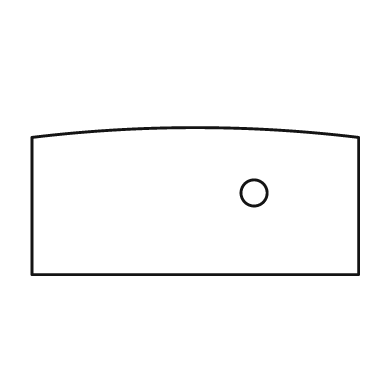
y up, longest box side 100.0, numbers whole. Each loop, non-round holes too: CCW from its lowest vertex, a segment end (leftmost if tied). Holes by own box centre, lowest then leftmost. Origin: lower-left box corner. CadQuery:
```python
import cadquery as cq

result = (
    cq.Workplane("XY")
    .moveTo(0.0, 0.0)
    .lineTo(100.0, 0.0)
    .lineTo(100.0, 42.0)
    .threePointArc((50.0, 45.0), (0.0, 42.0))
    .close()
    .moveTo(68.0, 25.0)
    .circle(4.0)
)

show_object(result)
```